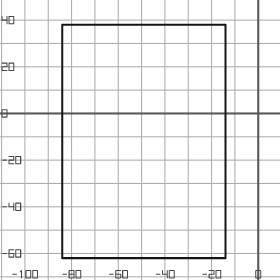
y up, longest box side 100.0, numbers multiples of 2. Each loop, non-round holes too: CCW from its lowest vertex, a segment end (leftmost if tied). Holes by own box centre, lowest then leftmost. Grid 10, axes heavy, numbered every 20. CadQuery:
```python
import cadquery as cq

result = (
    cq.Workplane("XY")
    .moveTo(-84.0, -62.0)
    .lineTo(-14.0, -62.0)
    .lineTo(-14.0, 38.0)
    .lineTo(-84.0, 38.0)
    .close()
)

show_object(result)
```